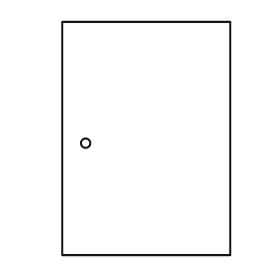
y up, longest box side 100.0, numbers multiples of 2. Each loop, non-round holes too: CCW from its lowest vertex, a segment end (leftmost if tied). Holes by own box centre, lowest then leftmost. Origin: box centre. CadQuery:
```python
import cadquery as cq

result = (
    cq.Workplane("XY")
    .moveTo(-36.0, -50.0)
    .lineTo(36.0, -50.0)
    .lineTo(36.0, 50.0)
    .lineTo(-36.0, 50.0)
    .close()
    .moveTo(-26.0, -2.0)
    .circle(2.0)
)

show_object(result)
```